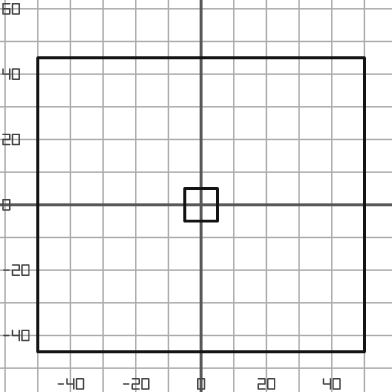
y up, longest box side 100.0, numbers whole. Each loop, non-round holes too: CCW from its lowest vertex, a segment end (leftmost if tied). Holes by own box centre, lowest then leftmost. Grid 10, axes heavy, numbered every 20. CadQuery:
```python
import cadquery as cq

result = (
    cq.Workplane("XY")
    .moveTo(-50.0, -45.0)
    .lineTo(50.0, -45.0)
    .lineTo(50.0, 45.0)
    .lineTo(-50.0, 45.0)
    .close()
    .moveTo(-5.0, -5.0)
    .lineTo(5.0, -5.0)
    .lineTo(5.0, 5.0)
    .lineTo(-5.0, 5.0)
    .close()
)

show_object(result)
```